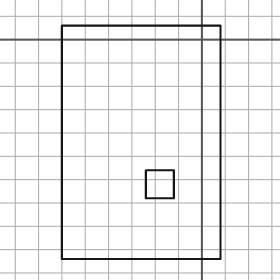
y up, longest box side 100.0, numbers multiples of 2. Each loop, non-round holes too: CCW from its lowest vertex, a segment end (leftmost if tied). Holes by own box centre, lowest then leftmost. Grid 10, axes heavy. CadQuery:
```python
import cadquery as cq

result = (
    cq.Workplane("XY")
    .moveTo(-60.0, -94.0)
    .lineTo(8.0, -94.0)
    .lineTo(8.0, 6.0)
    .lineTo(-60.0, 6.0)
    .close()
    .moveTo(-24.0, -68.0)
    .lineTo(-12.0, -68.0)
    .lineTo(-12.0, -56.0)
    .lineTo(-24.0, -56.0)
    .close()
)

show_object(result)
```